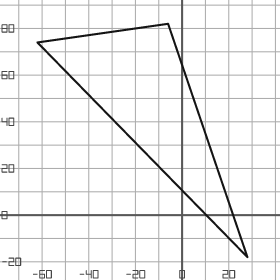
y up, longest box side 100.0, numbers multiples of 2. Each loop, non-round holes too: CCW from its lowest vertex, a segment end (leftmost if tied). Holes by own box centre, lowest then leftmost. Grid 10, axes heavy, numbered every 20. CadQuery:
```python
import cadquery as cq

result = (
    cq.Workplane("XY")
    .moveTo(28.0, -18.0)
    .lineTo(-6.0, 82.0)
    .lineTo(-62.0, 74.0)
    .close()
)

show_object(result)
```